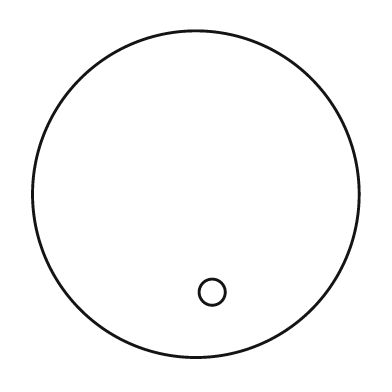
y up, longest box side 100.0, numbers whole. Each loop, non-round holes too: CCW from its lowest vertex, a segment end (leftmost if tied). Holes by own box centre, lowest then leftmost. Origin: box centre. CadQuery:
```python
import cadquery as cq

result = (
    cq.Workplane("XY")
    .moveTo(0.0, 0.0)
    .circle(50.0)
    .moveTo(5.0, -30.0)
    .circle(4.0)
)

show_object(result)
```